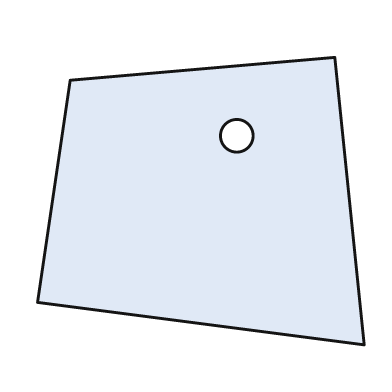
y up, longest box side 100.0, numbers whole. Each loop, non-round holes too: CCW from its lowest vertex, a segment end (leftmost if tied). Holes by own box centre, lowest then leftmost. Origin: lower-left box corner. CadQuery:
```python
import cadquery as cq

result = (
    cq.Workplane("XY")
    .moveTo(100.0, 0.0)
    .lineTo(91.0, 88.0)
    .lineTo(10.0, 81.0)
    .lineTo(0.0, 13.0)
    .close()
    .moveTo(61.0, 64.0)
    .circle(5.0)
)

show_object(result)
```